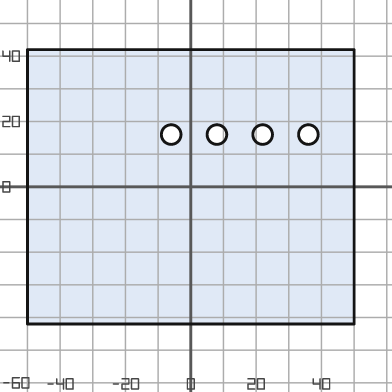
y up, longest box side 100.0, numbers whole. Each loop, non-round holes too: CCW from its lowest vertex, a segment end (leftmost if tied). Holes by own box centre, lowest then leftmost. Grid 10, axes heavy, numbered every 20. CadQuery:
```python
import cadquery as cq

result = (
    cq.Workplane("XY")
    .moveTo(-50.0, -42.0)
    .lineTo(50.0, -42.0)
    .lineTo(50.0, 42.0)
    .lineTo(-50.0, 42.0)
    .close()
    .moveTo(-6.0, 16.0)
    .circle(3.0)
    .moveTo(8.0, 16.0)
    .circle(3.0)
    .moveTo(22.0, 16.0)
    .circle(3.0)
    .moveTo(36.0, 16.0)
    .circle(3.0)
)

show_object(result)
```